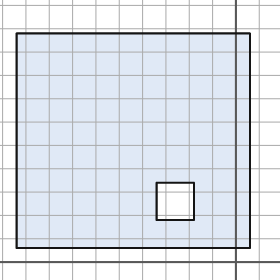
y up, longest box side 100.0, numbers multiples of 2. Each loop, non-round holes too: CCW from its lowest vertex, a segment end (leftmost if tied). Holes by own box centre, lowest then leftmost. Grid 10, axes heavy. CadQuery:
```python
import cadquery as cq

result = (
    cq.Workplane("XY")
    .moveTo(-94.0, 6.0)
    .lineTo(6.0, 6.0)
    .lineTo(6.0, 98.0)
    .lineTo(-94.0, 98.0)
    .close()
    .moveTo(-34.0, 18.0)
    .lineTo(-18.0, 18.0)
    .lineTo(-18.0, 34.0)
    .lineTo(-34.0, 34.0)
    .close()
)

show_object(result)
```